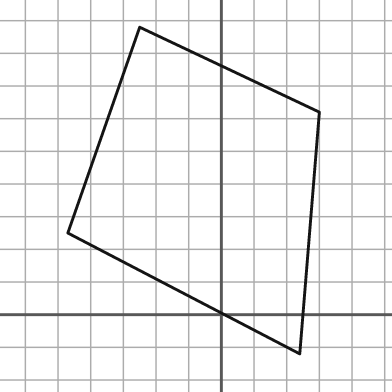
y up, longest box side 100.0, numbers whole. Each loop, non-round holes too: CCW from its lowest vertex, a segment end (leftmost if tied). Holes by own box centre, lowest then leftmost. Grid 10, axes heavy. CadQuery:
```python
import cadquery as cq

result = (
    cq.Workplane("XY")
    .moveTo(24.0, -12.0)
    .lineTo(30.0, 62.0)
    .lineTo(-25.0, 88.0)
    .lineTo(-47.0, 25.0)
    .close()
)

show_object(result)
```